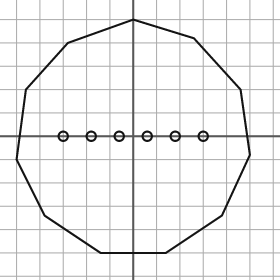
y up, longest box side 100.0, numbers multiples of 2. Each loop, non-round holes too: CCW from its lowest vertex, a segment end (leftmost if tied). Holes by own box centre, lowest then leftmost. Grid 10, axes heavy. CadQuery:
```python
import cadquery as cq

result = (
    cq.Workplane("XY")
    .moveTo(-14.0, -50.0)
    .lineTo(14.0, -50.0)
    .lineTo(38.0, -34.0)
    .lineTo(50.0, -8.0)
    .lineTo(46.0, 20.0)
    .lineTo(26.0, 42.0)
    .lineTo(0.0, 50.0)
    .lineTo(-28.0, 40.0)
    .lineTo(-46.0, 20.0)
    .lineTo(-50.0, -10.0)
    .lineTo(-38.0, -34.0)
    .close()
    .moveTo(-30.0, 0.0)
    .circle(2.0)
    .moveTo(-18.0, 0.0)
    .circle(2.0)
    .moveTo(-6.0, 0.0)
    .circle(2.0)
    .moveTo(6.0, 0.0)
    .circle(2.0)
    .moveTo(18.0, 0.0)
    .circle(2.0)
    .moveTo(30.0, 0.0)
    .circle(2.0)
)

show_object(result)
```